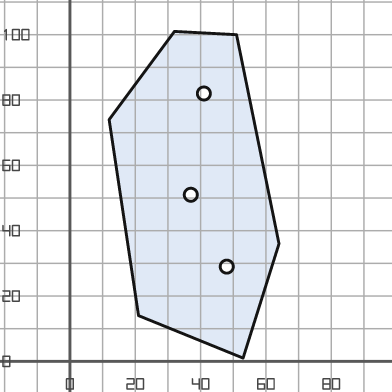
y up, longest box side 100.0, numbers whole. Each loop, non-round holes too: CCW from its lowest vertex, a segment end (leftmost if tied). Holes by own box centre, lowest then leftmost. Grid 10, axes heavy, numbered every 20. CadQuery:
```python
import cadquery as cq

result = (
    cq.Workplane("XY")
    .moveTo(53.0, 1.0)
    .lineTo(64.0, 36.0)
    .lineTo(51.0, 100.0)
    .lineTo(32.0, 101.0)
    .lineTo(12.0, 74.0)
    .lineTo(21.0, 14.0)
    .close()
    .moveTo(48.0, 29.0)
    .circle(2.0)
    .moveTo(37.0, 51.0)
    .circle(2.0)
    .moveTo(41.0, 82.0)
    .circle(2.0)
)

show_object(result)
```